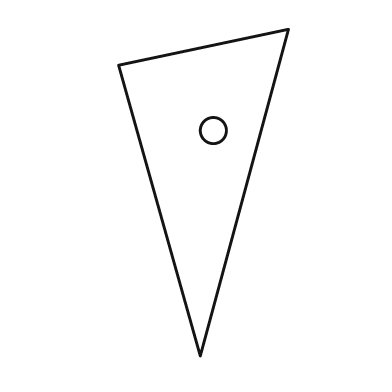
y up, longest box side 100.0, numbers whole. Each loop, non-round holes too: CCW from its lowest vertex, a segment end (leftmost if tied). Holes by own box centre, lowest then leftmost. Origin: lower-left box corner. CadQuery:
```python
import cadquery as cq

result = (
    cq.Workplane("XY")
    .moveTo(25.0, 0.0)
    .lineTo(52.0, 100.0)
    .lineTo(0.0, 89.0)
    .close()
    .moveTo(29.0, 69.0)
    .circle(4.0)
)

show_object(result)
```